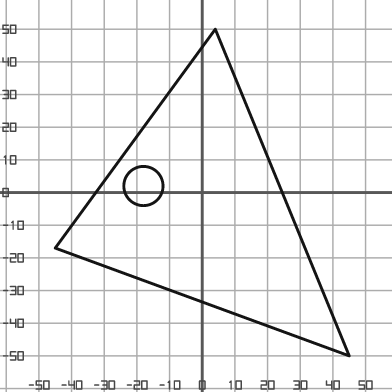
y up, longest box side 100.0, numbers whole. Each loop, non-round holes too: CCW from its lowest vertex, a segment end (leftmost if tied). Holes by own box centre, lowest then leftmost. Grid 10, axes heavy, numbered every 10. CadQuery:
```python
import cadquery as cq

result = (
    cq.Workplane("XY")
    .moveTo(45.0, -50.0)
    .lineTo(4.0, 50.0)
    .lineTo(-45.0, -17.0)
    .close()
    .moveTo(-18.0, 2.0)
    .circle(6.0)
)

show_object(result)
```